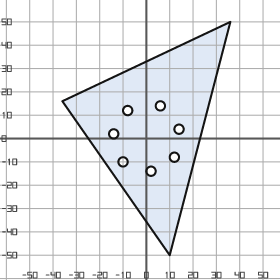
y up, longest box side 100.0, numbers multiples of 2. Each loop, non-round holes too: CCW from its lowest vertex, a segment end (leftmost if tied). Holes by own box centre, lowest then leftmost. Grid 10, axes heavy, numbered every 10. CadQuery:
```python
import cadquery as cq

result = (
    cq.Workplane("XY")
    .moveTo(10.0, -50.0)
    .lineTo(36.0, 50.0)
    .lineTo(-36.0, 16.0)
    .close()
    .moveTo(2.0, -14.0)
    .circle(2.0)
    .moveTo(-10.0, -10.0)
    .circle(2.0)
    .moveTo(12.0, -8.0)
    .circle(2.0)
    .moveTo(-14.0, 2.0)
    .circle(2.0)
    .moveTo(14.0, 4.0)
    .circle(2.0)
    .moveTo(-8.0, 12.0)
    .circle(2.0)
    .moveTo(6.0, 14.0)
    .circle(2.0)
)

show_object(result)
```